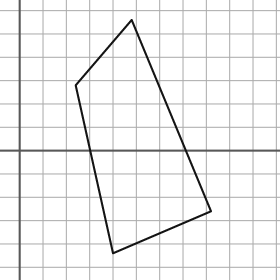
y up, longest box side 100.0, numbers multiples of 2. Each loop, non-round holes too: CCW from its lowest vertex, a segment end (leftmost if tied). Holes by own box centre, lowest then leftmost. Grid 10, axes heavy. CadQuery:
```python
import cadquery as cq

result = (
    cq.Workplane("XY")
    .moveTo(40.0, -44.0)
    .lineTo(82.0, -26.0)
    .lineTo(48.0, 56.0)
    .lineTo(24.0, 28.0)
    .close()
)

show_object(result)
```